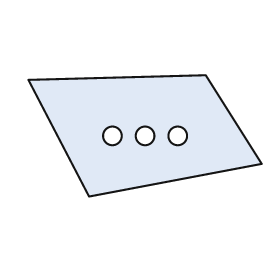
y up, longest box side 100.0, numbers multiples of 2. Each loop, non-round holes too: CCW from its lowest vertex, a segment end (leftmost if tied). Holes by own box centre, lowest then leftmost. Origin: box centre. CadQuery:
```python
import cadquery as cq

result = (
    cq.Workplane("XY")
    .moveTo(-24.0, -26.0)
    .lineTo(50.0, -12.0)
    .lineTo(26.0, 26.0)
    .lineTo(-50.0, 24.0)
    .close()
    .moveTo(-14.0, 0.0)
    .circle(4.0)
    .moveTo(0.0, 0.0)
    .circle(4.0)
    .moveTo(14.0, 0.0)
    .circle(4.0)
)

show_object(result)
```